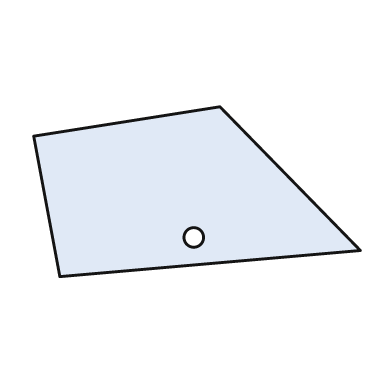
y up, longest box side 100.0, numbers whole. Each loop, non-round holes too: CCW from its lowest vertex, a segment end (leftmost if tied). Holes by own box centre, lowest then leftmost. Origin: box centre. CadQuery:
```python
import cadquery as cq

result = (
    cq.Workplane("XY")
    .moveTo(-42.0, -26.0)
    .lineTo(50.0, -18.0)
    .lineTo(7.0, 26.0)
    .lineTo(-50.0, 17.0)
    .close()
    .moveTo(-1.0, -14.0)
    .circle(3.0)
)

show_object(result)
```